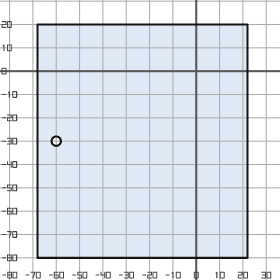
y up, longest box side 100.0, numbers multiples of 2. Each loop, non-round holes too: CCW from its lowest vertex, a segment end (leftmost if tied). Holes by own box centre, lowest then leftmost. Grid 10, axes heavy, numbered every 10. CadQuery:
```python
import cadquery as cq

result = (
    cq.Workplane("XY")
    .moveTo(-68.0, -80.0)
    .lineTo(22.0, -80.0)
    .lineTo(22.0, 20.0)
    .lineTo(-68.0, 20.0)
    .close()
    .moveTo(-60.0, -30.0)
    .circle(2.0)
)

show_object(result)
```